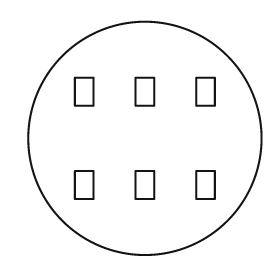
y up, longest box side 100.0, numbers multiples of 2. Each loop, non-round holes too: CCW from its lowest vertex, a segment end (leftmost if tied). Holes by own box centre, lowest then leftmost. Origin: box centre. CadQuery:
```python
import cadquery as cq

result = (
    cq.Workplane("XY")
    .moveTo(0.0, 0.0)
    .circle(50.0)
    .moveTo(-30.0, -26.0)
    .lineTo(-22.0, -26.0)
    .lineTo(-22.0, -14.0)
    .lineTo(-30.0, -14.0)
    .close()
    .moveTo(-4.0, -26.0)
    .lineTo(4.0, -26.0)
    .lineTo(4.0, -14.0)
    .lineTo(-4.0, -14.0)
    .close()
    .moveTo(22.0, -26.0)
    .lineTo(30.0, -26.0)
    .lineTo(30.0, -14.0)
    .lineTo(22.0, -14.0)
    .close()
    .moveTo(-30.0, 14.0)
    .lineTo(-22.0, 14.0)
    .lineTo(-22.0, 26.0)
    .lineTo(-30.0, 26.0)
    .close()
    .moveTo(-4.0, 14.0)
    .lineTo(4.0, 14.0)
    .lineTo(4.0, 26.0)
    .lineTo(-4.0, 26.0)
    .close()
    .moveTo(22.0, 14.0)
    .lineTo(30.0, 14.0)
    .lineTo(30.0, 26.0)
    .lineTo(22.0, 26.0)
    .close()
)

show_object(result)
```